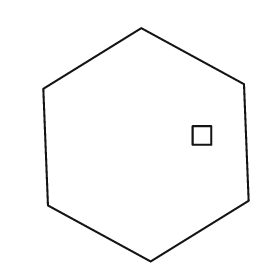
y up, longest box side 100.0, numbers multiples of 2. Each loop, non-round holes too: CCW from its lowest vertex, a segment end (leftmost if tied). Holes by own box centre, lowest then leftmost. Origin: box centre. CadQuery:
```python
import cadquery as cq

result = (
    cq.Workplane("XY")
    .moveTo(2.0, -50.0)
    .lineTo(44.0, -24.0)
    .lineTo(42.0, 26.0)
    .lineTo(-2.0, 50.0)
    .lineTo(-44.0, 24.0)
    .lineTo(-42.0, -26.0)
    .close()
    .moveTo(20.0, 0.0)
    .lineTo(28.0, 0.0)
    .lineTo(28.0, 8.0)
    .lineTo(20.0, 8.0)
    .close()
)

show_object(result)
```